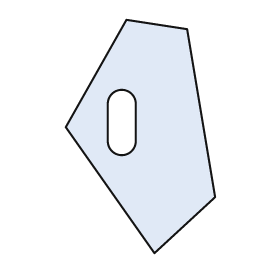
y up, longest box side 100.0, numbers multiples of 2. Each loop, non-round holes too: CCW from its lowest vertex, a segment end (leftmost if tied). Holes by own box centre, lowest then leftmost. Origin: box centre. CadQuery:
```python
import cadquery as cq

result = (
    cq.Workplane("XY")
    .moveTo(6.0, -50.0)
    .lineTo(32.0, -26.0)
    .lineTo(20.0, 46.0)
    .lineTo(-6.0, 50.0)
    .lineTo(-32.0, 4.0)
    .close()
    .moveTo(-14.0, -2.0)
    .threePointArc((-8.0, -8.0), (-2.0, -2.0))
    .lineTo(-2.0, 14.0)
    .threePointArc((-8.0, 20.0), (-14.0, 14.0))
    .close()
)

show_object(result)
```